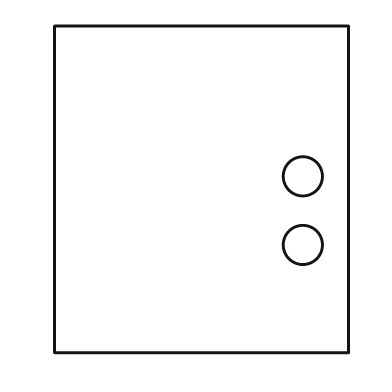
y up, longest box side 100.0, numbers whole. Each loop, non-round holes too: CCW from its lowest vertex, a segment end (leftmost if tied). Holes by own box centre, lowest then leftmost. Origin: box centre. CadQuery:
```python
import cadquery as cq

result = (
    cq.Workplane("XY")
    .moveTo(-45.0, -50.0)
    .lineTo(45.0, -50.0)
    .lineTo(45.0, 50.0)
    .lineTo(-45.0, 50.0)
    .close()
    .moveTo(31.0, -17.0)
    .circle(6.0)
    .moveTo(31.0, 4.0)
    .circle(6.0)
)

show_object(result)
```